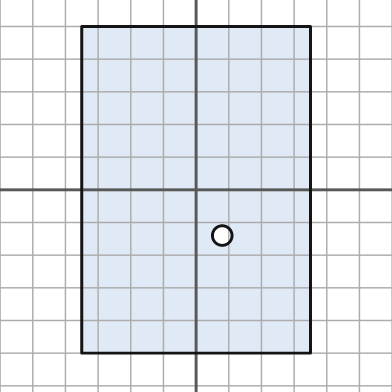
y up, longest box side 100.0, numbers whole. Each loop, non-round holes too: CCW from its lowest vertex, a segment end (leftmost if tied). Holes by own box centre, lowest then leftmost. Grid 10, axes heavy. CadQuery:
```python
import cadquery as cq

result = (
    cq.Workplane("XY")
    .moveTo(-35.0, -50.0)
    .lineTo(35.0, -50.0)
    .lineTo(35.0, 50.0)
    .lineTo(-35.0, 50.0)
    .close()
    .moveTo(8.0, -14.0)
    .circle(3.0)
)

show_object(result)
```